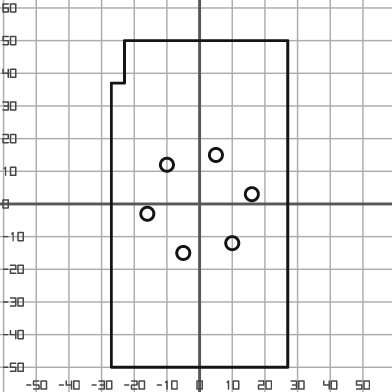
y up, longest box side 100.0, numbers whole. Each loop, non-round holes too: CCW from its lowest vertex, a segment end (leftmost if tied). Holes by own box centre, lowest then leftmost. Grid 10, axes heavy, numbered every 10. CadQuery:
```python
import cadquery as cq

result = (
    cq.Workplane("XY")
    .moveTo(-27.0, -50.0)
    .lineTo(27.0, -50.0)
    .lineTo(27.0, 50.0)
    .lineTo(-23.0, 50.0)
    .lineTo(-23.0, 37.0)
    .lineTo(-27.0, 37.0)
    .close()
    .moveTo(-5.0, -15.0)
    .circle(2.0)
    .moveTo(10.0, -12.0)
    .circle(2.0)
    .moveTo(-16.0, -3.0)
    .circle(2.0)
    .moveTo(16.0, 3.0)
    .circle(2.0)
    .moveTo(-10.0, 12.0)
    .circle(2.0)
    .moveTo(5.0, 15.0)
    .circle(2.0)
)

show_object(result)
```